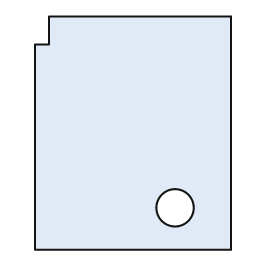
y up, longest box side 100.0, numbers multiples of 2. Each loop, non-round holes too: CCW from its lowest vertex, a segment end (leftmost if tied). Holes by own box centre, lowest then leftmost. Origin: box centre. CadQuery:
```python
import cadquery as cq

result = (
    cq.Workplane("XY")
    .moveTo(-42.0, -50.0)
    .lineTo(42.0, -50.0)
    .lineTo(42.0, 50.0)
    .lineTo(-36.0, 50.0)
    .lineTo(-36.0, 38.0)
    .lineTo(-42.0, 38.0)
    .close()
    .moveTo(18.0, -32.0)
    .circle(8.0)
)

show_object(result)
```